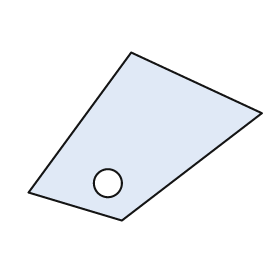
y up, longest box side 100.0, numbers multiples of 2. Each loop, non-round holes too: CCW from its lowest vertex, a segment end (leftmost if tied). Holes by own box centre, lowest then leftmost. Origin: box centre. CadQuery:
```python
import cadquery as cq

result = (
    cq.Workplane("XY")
    .moveTo(-10.0, -36.0)
    .lineTo(50.0, 10.0)
    .lineTo(-6.0, 36.0)
    .lineTo(-50.0, -24.0)
    .close()
    .moveTo(-16.0, -20.0)
    .circle(6.0)
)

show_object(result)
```